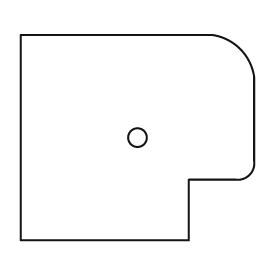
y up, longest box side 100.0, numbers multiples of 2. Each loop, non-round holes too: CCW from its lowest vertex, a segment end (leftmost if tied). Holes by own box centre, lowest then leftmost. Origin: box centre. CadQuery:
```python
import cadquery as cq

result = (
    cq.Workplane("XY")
    .moveTo(-50.0, -44.0)
    .lineTo(22.0, -44.0)
    .lineTo(22.0, -18.0)
    .lineTo(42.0, -18.0)
    .threePointArc((48.0, -16.0), (50.0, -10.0))
    .lineTo(50.0, 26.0)
    .threePointArc((44.0, 38.0), (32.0, 44.0))
    .lineTo(-50.0, 44.0)
    .close()
    .moveTo(0.0, 0.0)
    .circle(4.0)
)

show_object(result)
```